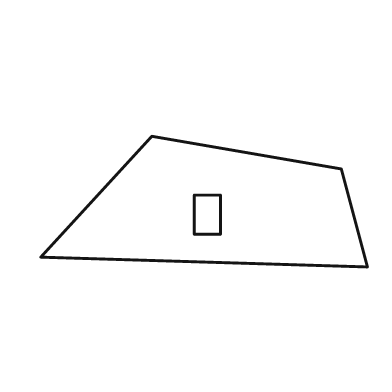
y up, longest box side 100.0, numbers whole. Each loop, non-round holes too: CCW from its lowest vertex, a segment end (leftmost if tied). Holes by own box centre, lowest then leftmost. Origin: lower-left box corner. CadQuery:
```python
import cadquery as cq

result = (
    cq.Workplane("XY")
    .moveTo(100.0, 0.0)
    .lineTo(92.0, 30.0)
    .lineTo(34.0, 40.0)
    .lineTo(0.0, 3.0)
    .close()
    .moveTo(47.0, 10.0)
    .lineTo(55.0, 10.0)
    .lineTo(55.0, 22.0)
    .lineTo(47.0, 22.0)
    .close()
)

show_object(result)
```